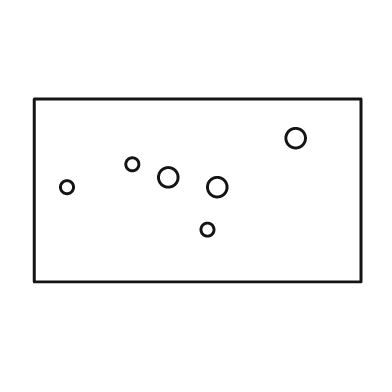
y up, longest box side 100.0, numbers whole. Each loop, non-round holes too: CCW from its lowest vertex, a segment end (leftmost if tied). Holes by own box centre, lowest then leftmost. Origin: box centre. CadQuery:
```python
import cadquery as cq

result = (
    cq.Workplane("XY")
    .moveTo(-50.0, -28.0)
    .lineTo(50.0, -28.0)
    .lineTo(50.0, 28.0)
    .lineTo(-50.0, 28.0)
    .close()
    .moveTo(3.0, -12.0)
    .circle(2.0)
    .moveTo(-40.0, 1.0)
    .circle(2.0)
    .moveTo(6.0, 1.0)
    .circle(3.0)
    .moveTo(-9.0, 4.0)
    .circle(3.0)
    .moveTo(-20.0, 8.0)
    .circle(2.0)
    .moveTo(30.0, 16.0)
    .circle(3.0)
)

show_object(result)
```